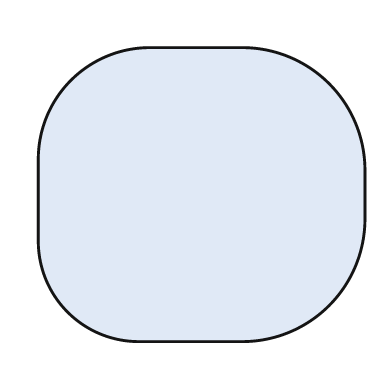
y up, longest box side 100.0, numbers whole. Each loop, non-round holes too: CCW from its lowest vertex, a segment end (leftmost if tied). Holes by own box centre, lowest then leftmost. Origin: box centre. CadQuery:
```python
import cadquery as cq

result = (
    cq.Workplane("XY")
    .moveTo(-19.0, -45.0)
    .lineTo(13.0, -45.0)
    .threePointArc((39.0, -34.0), (50.0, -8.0))
    .lineTo(50.0, 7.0)
    .threePointArc((39.0, 34.0), (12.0, 45.0))
    .lineTo(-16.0, 45.0)
    .threePointArc((-40.0, 35.0), (-50.0, 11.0))
    .lineTo(-50.0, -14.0)
    .threePointArc((-41.0, -36.0), (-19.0, -45.0))
    .close()
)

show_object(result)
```